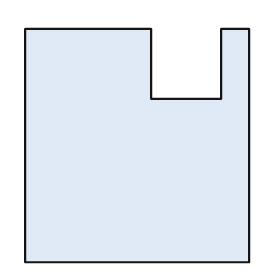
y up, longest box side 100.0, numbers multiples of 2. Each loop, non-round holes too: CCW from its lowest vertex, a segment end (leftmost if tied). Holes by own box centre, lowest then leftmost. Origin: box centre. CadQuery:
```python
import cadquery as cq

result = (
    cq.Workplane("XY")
    .moveTo(-48.0, -50.0)
    .lineTo(48.0, -50.0)
    .lineTo(48.0, 50.0)
    .lineTo(36.0, 50.0)
    .lineTo(36.0, 20.0)
    .lineTo(6.0, 20.0)
    .lineTo(6.0, 50.0)
    .lineTo(-48.0, 50.0)
    .close()
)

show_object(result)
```